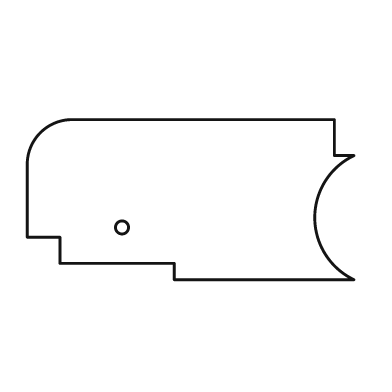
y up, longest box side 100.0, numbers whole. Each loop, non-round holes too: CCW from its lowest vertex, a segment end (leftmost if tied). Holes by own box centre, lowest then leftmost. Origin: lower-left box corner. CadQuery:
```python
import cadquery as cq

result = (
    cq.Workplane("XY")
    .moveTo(45.0, 0.0)
    .lineTo(100.0, 0.0)
    .threePointArc((88.0, 19.0), (100.0, 38.0))
    .lineTo(94.0, 38.0)
    .lineTo(94.0, 49.0)
    .lineTo(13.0, 49.0)
    .threePointArc((4.0, 45.0), (0.0, 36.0))
    .lineTo(0.0, 13.0)
    .lineTo(10.0, 13.0)
    .lineTo(10.0, 5.0)
    .lineTo(45.0, 5.0)
    .close()
    .moveTo(29.0, 16.0)
    .circle(2.0)
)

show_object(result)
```